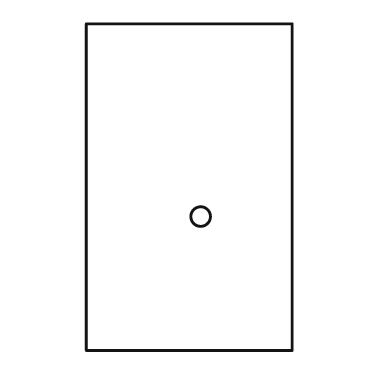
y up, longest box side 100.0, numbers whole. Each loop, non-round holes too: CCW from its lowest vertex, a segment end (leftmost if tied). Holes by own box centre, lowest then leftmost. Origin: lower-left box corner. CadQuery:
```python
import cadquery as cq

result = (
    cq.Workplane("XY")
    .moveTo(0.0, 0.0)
    .lineTo(63.0, 0.0)
    .lineTo(63.0, 100.0)
    .lineTo(0.0, 100.0)
    .close()
    .moveTo(35.0, 41.0)
    .circle(3.0)
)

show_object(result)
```